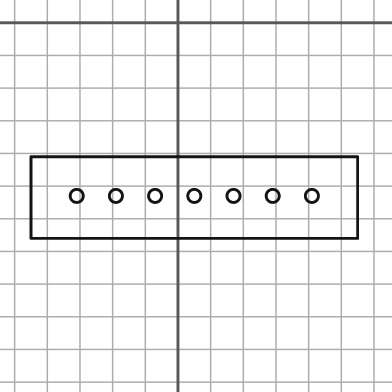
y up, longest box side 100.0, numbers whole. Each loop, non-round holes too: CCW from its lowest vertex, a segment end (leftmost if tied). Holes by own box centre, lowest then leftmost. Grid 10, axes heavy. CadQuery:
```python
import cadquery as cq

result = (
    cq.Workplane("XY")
    .moveTo(-45.0, -66.0)
    .lineTo(55.0, -66.0)
    .lineTo(55.0, -41.0)
    .lineTo(-45.0, -41.0)
    .close()
    .moveTo(-31.0, -53.0)
    .circle(2.0)
    .moveTo(-19.0, -53.0)
    .circle(2.0)
    .moveTo(-7.0, -53.0)
    .circle(2.0)
    .moveTo(5.0, -53.0)
    .circle(2.0)
    .moveTo(17.0, -53.0)
    .circle(2.0)
    .moveTo(29.0, -53.0)
    .circle(2.0)
    .moveTo(41.0, -53.0)
    .circle(2.0)
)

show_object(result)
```